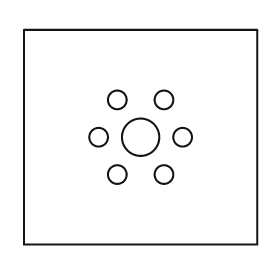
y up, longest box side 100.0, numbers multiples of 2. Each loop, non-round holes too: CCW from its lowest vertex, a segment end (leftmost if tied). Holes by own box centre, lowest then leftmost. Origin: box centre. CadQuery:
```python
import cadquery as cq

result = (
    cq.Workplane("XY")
    .moveTo(-50.0, -46.0)
    .lineTo(50.0, -46.0)
    .lineTo(50.0, 46.0)
    .lineTo(-50.0, 46.0)
    .close()
    .moveTo(-10.0, -16.0)
    .circle(4.0)
    .moveTo(10.0, -16.0)
    .circle(4.0)
    .moveTo(-18.0, 0.0)
    .circle(4.0)
    .moveTo(0.0, 0.0)
    .circle(8.0)
    .moveTo(18.0, 0.0)
    .circle(4.0)
    .moveTo(-10.0, 16.0)
    .circle(4.0)
    .moveTo(10.0, 16.0)
    .circle(4.0)
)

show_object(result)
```